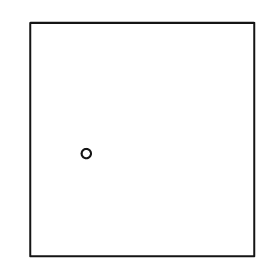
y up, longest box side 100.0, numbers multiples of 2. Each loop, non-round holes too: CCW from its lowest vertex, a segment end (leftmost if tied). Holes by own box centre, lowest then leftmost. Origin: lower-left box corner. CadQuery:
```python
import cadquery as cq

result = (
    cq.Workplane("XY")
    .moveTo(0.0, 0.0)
    .lineTo(96.0, 0.0)
    .lineTo(96.0, 100.0)
    .lineTo(0.0, 100.0)
    .close()
    .moveTo(24.0, 44.0)
    .circle(2.0)
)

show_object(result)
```